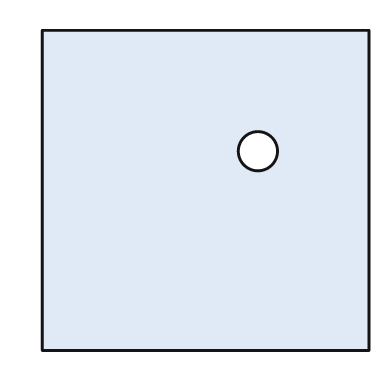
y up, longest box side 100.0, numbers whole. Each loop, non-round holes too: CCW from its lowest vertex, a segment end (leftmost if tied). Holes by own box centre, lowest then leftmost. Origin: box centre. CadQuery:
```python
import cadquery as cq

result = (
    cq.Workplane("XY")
    .moveTo(-50.0, -49.0)
    .lineTo(50.0, -49.0)
    .lineTo(50.0, 49.0)
    .lineTo(-50.0, 49.0)
    .close()
    .moveTo(16.0, 12.0)
    .circle(6.0)
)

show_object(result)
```